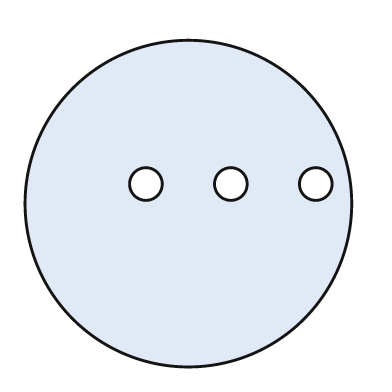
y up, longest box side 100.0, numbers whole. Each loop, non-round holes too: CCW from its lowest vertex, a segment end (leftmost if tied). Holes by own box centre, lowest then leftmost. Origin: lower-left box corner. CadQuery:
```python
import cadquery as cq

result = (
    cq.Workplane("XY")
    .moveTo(50.0, 50.0)
    .circle(50.0)
    .moveTo(37.0, 56.0)
    .circle(5.0)
    .moveTo(63.0, 56.0)
    .circle(5.0)
    .moveTo(89.0, 56.0)
    .circle(5.0)
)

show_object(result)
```